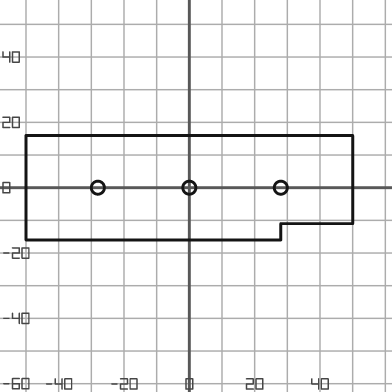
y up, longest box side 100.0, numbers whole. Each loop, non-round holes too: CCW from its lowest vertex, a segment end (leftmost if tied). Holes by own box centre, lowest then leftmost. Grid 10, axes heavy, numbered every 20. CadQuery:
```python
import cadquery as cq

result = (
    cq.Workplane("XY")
    .moveTo(-50.0, -16.0)
    .lineTo(28.0, -16.0)
    .lineTo(28.0, -11.0)
    .lineTo(50.0, -11.0)
    .lineTo(50.0, 16.0)
    .lineTo(-50.0, 16.0)
    .close()
    .moveTo(-28.0, 0.0)
    .circle(2.0)
    .moveTo(0.0, 0.0)
    .circle(2.0)
    .moveTo(28.0, 0.0)
    .circle(2.0)
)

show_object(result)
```